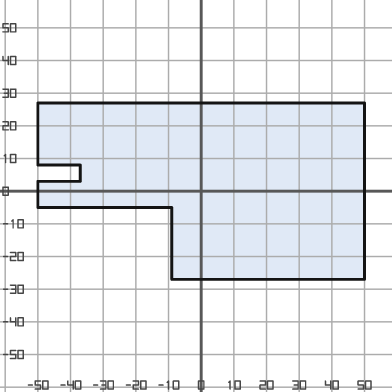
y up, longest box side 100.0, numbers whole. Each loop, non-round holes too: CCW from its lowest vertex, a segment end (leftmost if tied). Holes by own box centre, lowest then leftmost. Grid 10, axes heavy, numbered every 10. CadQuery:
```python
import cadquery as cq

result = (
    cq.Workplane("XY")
    .moveTo(-9.0, -27.0)
    .lineTo(50.0, -27.0)
    .lineTo(50.0, 27.0)
    .lineTo(-50.0, 27.0)
    .lineTo(-50.0, 8.0)
    .lineTo(-37.0, 8.0)
    .lineTo(-37.0, 3.0)
    .lineTo(-50.0, 3.0)
    .lineTo(-50.0, -5.0)
    .lineTo(-9.0, -5.0)
    .close()
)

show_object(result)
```